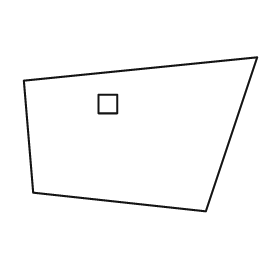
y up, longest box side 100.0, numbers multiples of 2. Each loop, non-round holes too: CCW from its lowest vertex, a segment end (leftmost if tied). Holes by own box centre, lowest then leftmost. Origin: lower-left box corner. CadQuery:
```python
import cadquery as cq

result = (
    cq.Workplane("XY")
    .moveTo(78.0, 0.0)
    .lineTo(100.0, 66.0)
    .lineTo(0.0, 56.0)
    .lineTo(4.0, 8.0)
    .close()
    .moveTo(32.0, 42.0)
    .lineTo(40.0, 42.0)
    .lineTo(40.0, 50.0)
    .lineTo(32.0, 50.0)
    .close()
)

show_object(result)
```